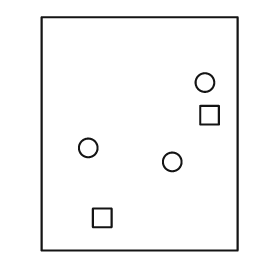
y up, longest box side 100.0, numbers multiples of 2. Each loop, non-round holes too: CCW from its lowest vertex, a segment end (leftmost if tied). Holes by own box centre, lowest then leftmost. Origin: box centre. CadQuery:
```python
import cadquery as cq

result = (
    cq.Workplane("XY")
    .moveTo(-42.0, -50.0)
    .lineTo(42.0, -50.0)
    .lineTo(42.0, 50.0)
    .lineTo(-42.0, 50.0)
    .close()
    .moveTo(-20.0, -40.0)
    .lineTo(-12.0, -40.0)
    .lineTo(-12.0, -32.0)
    .lineTo(-20.0, -32.0)
    .close()
    .moveTo(14.0, -12.0)
    .circle(4.0)
    .moveTo(-22.0, -6.0)
    .circle(4.0)
    .moveTo(26.0, 4.0)
    .lineTo(34.0, 4.0)
    .lineTo(34.0, 12.0)
    .lineTo(26.0, 12.0)
    .close()
    .moveTo(28.0, 22.0)
    .circle(4.0)
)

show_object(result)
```